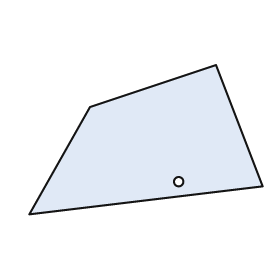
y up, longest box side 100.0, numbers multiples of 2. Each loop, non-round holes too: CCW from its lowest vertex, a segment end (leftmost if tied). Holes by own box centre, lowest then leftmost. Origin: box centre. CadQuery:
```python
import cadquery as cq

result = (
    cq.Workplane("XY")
    .moveTo(-50.0, -32.0)
    .lineTo(50.0, -20.0)
    .lineTo(30.0, 32.0)
    .lineTo(-24.0, 14.0)
    .close()
    .moveTo(14.0, -18.0)
    .circle(2.0)
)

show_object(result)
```